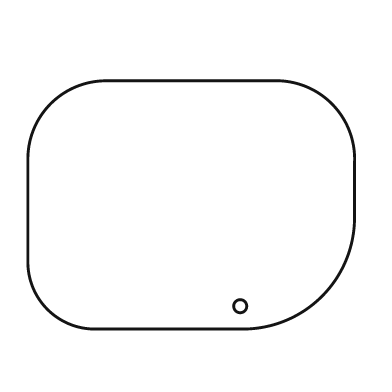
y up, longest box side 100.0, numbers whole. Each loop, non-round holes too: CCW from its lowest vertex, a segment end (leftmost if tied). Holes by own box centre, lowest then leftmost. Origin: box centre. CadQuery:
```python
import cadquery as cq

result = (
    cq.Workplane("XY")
    .moveTo(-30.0, -38.0)
    .lineTo(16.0, -38.0)
    .threePointArc((40.0, -28.0), (50.0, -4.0))
    .lineTo(50.0, 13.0)
    .threePointArc((43.0, 31.0), (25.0, 38.0))
    .lineTo(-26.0, 38.0)
    .threePointArc((-43.0, 31.0), (-50.0, 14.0))
    .lineTo(-50.0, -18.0)
    .threePointArc((-44.0, -32.0), (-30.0, -38.0))
    .close()
    .moveTo(15.0, -31.0)
    .circle(2.0)
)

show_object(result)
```